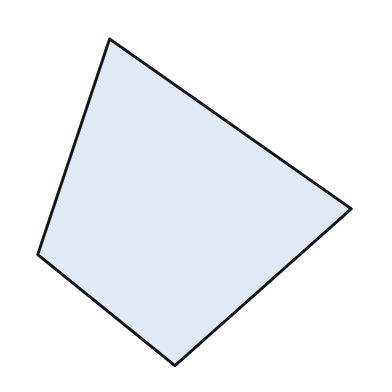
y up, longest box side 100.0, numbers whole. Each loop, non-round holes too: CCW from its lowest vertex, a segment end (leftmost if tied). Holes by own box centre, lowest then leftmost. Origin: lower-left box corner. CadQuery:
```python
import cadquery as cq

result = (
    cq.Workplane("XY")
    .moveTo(42.0, 0.0)
    .lineTo(96.0, 48.0)
    .lineTo(22.0, 100.0)
    .lineTo(0.0, 34.0)
    .close()
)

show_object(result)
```